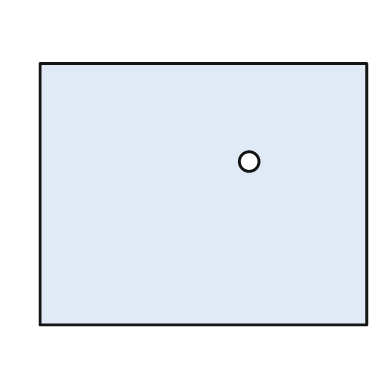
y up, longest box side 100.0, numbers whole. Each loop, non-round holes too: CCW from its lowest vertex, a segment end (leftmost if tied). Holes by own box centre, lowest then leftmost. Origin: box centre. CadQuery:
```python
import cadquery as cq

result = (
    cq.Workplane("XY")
    .moveTo(-50.0, -40.0)
    .lineTo(50.0, -40.0)
    .lineTo(50.0, 40.0)
    .lineTo(-50.0, 40.0)
    .close()
    .moveTo(14.0, 10.0)
    .circle(3.0)
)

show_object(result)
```